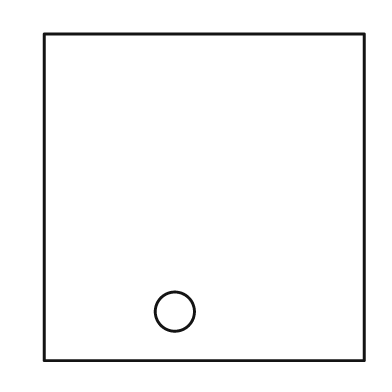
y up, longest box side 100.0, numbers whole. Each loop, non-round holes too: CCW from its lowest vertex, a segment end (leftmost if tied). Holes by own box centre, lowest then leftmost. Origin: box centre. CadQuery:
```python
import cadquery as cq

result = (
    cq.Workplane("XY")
    .moveTo(-49.0, -50.0)
    .lineTo(49.0, -50.0)
    .lineTo(49.0, 50.0)
    .lineTo(-49.0, 50.0)
    .close()
    .moveTo(-9.0, -35.0)
    .circle(6.0)
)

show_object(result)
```